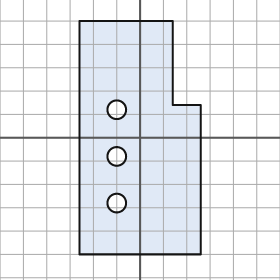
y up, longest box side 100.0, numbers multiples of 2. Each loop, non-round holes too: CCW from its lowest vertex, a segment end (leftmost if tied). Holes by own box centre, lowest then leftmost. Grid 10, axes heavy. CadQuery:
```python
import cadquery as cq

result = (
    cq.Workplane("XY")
    .moveTo(-26.0, -50.0)
    .lineTo(26.0, -50.0)
    .lineTo(26.0, 14.0)
    .lineTo(14.0, 14.0)
    .lineTo(14.0, 50.0)
    .lineTo(-26.0, 50.0)
    .close()
    .moveTo(-10.0, -28.0)
    .circle(4.0)
    .moveTo(-10.0, -8.0)
    .circle(4.0)
    .moveTo(-10.0, 12.0)
    .circle(4.0)
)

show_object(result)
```